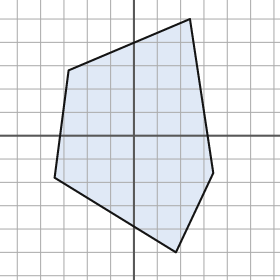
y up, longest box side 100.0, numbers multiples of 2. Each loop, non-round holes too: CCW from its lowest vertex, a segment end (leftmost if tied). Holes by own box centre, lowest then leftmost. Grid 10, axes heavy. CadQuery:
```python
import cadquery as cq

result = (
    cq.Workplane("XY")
    .moveTo(18.0, -50.0)
    .lineTo(34.0, -16.0)
    .lineTo(24.0, 50.0)
    .lineTo(-28.0, 28.0)
    .lineTo(-34.0, -18.0)
    .close()
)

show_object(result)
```